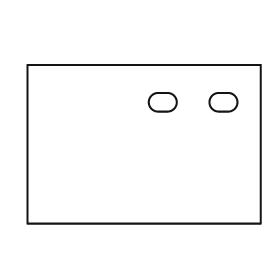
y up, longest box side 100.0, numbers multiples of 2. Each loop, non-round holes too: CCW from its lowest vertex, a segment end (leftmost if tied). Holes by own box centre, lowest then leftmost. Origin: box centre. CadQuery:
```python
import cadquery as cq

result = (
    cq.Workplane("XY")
    .moveTo(-50.0, -34.0)
    .lineTo(50.0, -34.0)
    .lineTo(50.0, 34.0)
    .lineTo(-50.0, 34.0)
    .close()
    .moveTo(6.0, 14.0)
    .lineTo(10.0, 14.0)
    .threePointArc((14.0, 18.0), (10.0, 22.0))
    .lineTo(6.0, 22.0)
    .threePointArc((2.0, 18.0), (6.0, 14.0))
    .close()
    .moveTo(32.0, 14.0)
    .lineTo(36.0, 14.0)
    .threePointArc((40.0, 18.0), (36.0, 22.0))
    .lineTo(32.0, 22.0)
    .threePointArc((28.0, 18.0), (32.0, 14.0))
    .close()
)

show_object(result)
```